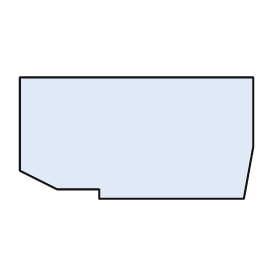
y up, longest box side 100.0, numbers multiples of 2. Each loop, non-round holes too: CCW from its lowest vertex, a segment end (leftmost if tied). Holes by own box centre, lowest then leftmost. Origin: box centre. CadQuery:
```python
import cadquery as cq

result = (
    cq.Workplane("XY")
    .moveTo(-16.0, -26.0)
    .lineTo(46.0, -26.0)
    .lineTo(50.0, -4.0)
    .lineTo(50.0, 26.0)
    .lineTo(-50.0, 26.0)
    .lineTo(-50.0, -14.0)
    .lineTo(-34.0, -22.0)
    .lineTo(-16.0, -22.0)
    .close()
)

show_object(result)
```